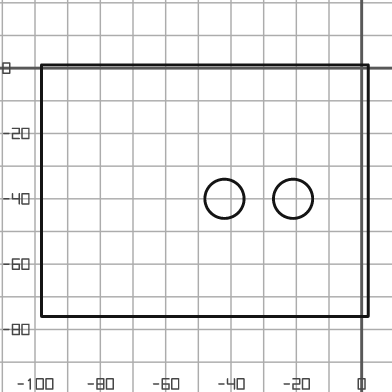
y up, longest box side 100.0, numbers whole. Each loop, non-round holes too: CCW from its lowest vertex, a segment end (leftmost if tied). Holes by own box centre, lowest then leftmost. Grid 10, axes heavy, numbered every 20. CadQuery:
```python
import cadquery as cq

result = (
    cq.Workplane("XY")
    .moveTo(-98.0, -76.0)
    .lineTo(2.0, -76.0)
    .lineTo(2.0, 1.0)
    .lineTo(-98.0, 1.0)
    .close()
    .moveTo(-42.0, -40.0)
    .circle(6.0)
    .moveTo(-21.0, -40.0)
    .circle(6.0)
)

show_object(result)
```